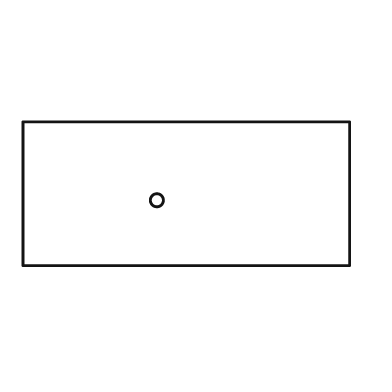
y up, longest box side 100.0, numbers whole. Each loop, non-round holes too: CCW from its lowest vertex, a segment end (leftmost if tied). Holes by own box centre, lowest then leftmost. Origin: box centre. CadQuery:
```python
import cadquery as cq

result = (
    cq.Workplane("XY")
    .moveTo(-50.0, -22.0)
    .lineTo(50.0, -22.0)
    .lineTo(50.0, 22.0)
    .lineTo(-50.0, 22.0)
    .close()
    .moveTo(-9.0, -2.0)
    .circle(2.0)
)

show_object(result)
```